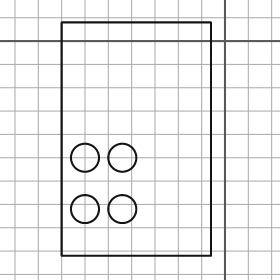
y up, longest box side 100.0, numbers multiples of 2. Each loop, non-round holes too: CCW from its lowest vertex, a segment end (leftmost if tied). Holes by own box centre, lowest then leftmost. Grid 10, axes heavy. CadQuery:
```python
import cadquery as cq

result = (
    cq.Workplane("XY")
    .moveTo(-70.0, -92.0)
    .lineTo(-6.0, -92.0)
    .lineTo(-6.0, 8.0)
    .lineTo(-70.0, 8.0)
    .close()
    .moveTo(-60.0, -72.0)
    .circle(6.0)
    .moveTo(-44.0, -72.0)
    .circle(6.0)
    .moveTo(-60.0, -50.0)
    .circle(6.0)
    .moveTo(-44.0, -50.0)
    .circle(6.0)
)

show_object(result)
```